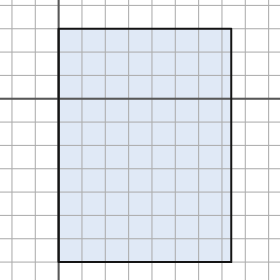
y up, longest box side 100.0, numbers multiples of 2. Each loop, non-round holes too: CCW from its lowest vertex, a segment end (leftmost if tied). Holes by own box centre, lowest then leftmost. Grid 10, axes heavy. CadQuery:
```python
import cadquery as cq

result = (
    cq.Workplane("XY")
    .moveTo(0.0, -70.0)
    .lineTo(74.0, -70.0)
    .lineTo(74.0, 30.0)
    .lineTo(0.0, 30.0)
    .close()
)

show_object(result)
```